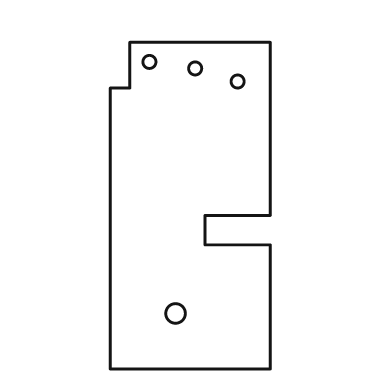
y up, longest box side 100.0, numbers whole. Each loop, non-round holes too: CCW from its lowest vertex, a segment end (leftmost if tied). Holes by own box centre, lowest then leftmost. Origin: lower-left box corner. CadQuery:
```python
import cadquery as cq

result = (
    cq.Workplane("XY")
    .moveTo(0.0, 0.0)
    .lineTo(49.0, 0.0)
    .lineTo(49.0, 38.0)
    .lineTo(29.0, 38.0)
    .lineTo(29.0, 47.0)
    .lineTo(49.0, 47.0)
    .lineTo(49.0, 100.0)
    .lineTo(6.0, 100.0)
    .lineTo(6.0, 86.0)
    .lineTo(0.0, 86.0)
    .close()
    .moveTo(20.0, 17.0)
    .circle(3.0)
    .moveTo(39.0, 88.0)
    .circle(2.0)
    .moveTo(26.0, 92.0)
    .circle(2.0)
    .moveTo(12.0, 94.0)
    .circle(2.0)
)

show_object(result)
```